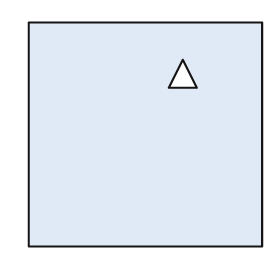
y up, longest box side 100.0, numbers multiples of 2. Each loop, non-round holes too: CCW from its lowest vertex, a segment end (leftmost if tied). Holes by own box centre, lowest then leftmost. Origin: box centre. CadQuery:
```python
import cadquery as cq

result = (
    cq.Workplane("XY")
    .moveTo(-50.0, -48.0)
    .lineTo(50.0, -48.0)
    .lineTo(50.0, 48.0)
    .lineTo(-50.0, 48.0)
    .close()
    .moveTo(10.0, 20.0)
    .lineTo(22.0, 20.0)
    .lineTo(16.0, 32.0)
    .close()
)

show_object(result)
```